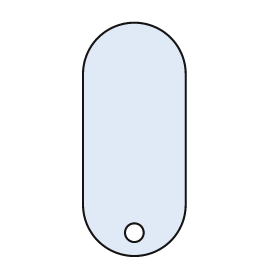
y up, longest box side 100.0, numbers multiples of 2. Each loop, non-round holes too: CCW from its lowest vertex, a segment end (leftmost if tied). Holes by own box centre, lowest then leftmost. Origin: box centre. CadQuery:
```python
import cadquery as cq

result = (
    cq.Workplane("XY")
    .moveTo(-22.0, -28.0)
    .threePointArc((0.0, -50.0), (22.0, -28.0))
    .lineTo(22.0, 28.0)
    .threePointArc((0.0, 50.0), (-22.0, 28.0))
    .close()
    .moveTo(0.0, -40.0)
    .circle(4.0)
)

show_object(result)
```